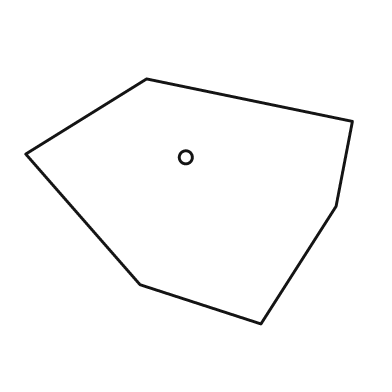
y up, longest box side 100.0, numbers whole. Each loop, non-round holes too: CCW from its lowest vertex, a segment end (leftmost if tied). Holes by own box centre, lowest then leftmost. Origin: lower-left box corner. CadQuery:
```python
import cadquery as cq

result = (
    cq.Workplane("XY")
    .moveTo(72.0, 0.0)
    .lineTo(95.0, 36.0)
    .lineTo(100.0, 62.0)
    .lineTo(37.0, 75.0)
    .lineTo(0.0, 52.0)
    .lineTo(35.0, 12.0)
    .close()
    .moveTo(49.0, 51.0)
    .circle(2.0)
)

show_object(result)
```